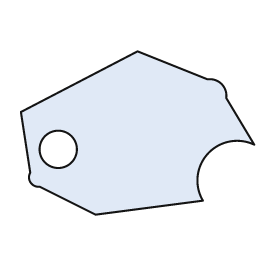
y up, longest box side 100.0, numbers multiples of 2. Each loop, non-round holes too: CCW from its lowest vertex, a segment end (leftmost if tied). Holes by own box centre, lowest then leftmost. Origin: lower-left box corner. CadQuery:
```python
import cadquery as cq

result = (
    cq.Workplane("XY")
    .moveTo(32.0, 0.0)
    .lineTo(78.0, 6.0)
    .threePointArc((80.0, 26.0), (100.0, 30.0))
    .lineTo(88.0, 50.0)
    .threePointArc((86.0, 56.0), (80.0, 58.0))
    .lineTo(50.0, 70.0)
    .lineTo(0.0, 44.0)
    .lineTo(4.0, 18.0)
    .threePointArc((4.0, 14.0), (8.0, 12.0))
    .close()
    .moveTo(16.0, 28.0)
    .circle(8.0)
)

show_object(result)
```